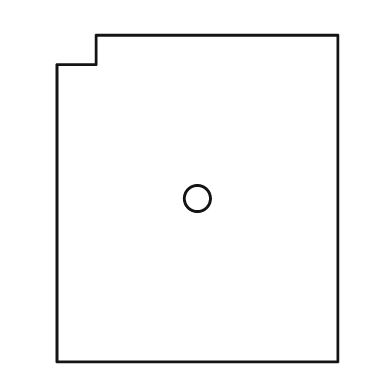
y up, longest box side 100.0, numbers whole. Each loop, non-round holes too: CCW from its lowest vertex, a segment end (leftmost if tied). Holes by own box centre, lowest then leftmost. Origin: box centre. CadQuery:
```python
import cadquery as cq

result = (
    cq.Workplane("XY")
    .moveTo(-43.0, -50.0)
    .lineTo(43.0, -50.0)
    .lineTo(43.0, 50.0)
    .lineTo(-31.0, 50.0)
    .lineTo(-31.0, 41.0)
    .lineTo(-43.0, 41.0)
    .close()
    .moveTo(0.0, 0.0)
    .circle(4.0)
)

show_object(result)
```